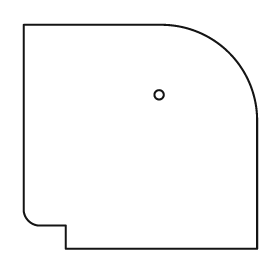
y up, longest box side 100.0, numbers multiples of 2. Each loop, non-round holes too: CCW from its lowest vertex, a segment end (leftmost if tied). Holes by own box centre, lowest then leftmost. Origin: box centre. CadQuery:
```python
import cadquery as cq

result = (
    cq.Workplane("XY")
    .moveTo(-32.0, -48.0)
    .lineTo(50.0, -48.0)
    .lineTo(50.0, 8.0)
    .threePointArc((38.0, 36.0), (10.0, 48.0))
    .lineTo(-50.0, 48.0)
    .lineTo(-50.0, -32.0)
    .threePointArc((-48.0, -36.0), (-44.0, -38.0))
    .lineTo(-32.0, -38.0)
    .close()
    .moveTo(8.0, 18.0)
    .circle(2.0)
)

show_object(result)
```